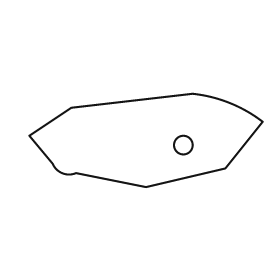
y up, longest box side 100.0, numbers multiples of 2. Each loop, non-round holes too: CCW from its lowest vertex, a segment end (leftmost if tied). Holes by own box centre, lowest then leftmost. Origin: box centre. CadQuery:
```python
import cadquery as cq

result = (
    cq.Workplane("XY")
    .moveTo(0.0, -20.0)
    .lineTo(34.0, -12.0)
    .lineTo(50.0, 8.0)
    .threePointArc((36.0, 16.0), (20.0, 20.0))
    .lineTo(-32.0, 14.0)
    .lineTo(-50.0, 2.0)
    .lineTo(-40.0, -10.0)
    .threePointArc((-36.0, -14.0), (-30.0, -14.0))
    .close()
    .moveTo(16.0, -2.0)
    .circle(4.0)
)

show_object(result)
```